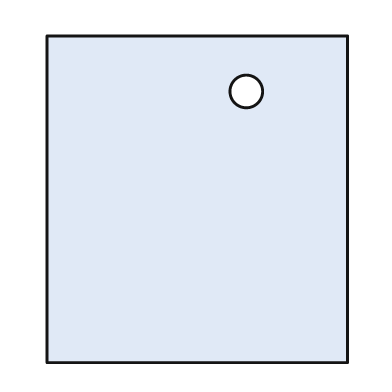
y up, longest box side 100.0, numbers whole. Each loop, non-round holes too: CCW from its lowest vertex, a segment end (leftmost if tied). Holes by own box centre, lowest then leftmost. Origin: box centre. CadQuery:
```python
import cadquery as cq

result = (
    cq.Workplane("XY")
    .moveTo(-46.0, -50.0)
    .lineTo(46.0, -50.0)
    .lineTo(46.0, 50.0)
    .lineTo(-46.0, 50.0)
    .close()
    .moveTo(15.0, 33.0)
    .circle(5.0)
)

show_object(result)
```